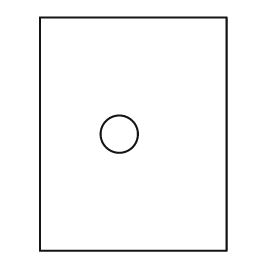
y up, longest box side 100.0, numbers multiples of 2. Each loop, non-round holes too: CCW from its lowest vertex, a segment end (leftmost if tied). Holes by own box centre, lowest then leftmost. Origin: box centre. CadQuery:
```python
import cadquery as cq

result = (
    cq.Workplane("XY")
    .moveTo(-40.0, -50.0)
    .lineTo(40.0, -50.0)
    .lineTo(40.0, 50.0)
    .lineTo(-40.0, 50.0)
    .close()
    .moveTo(-6.0, 0.0)
    .circle(8.0)
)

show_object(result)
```